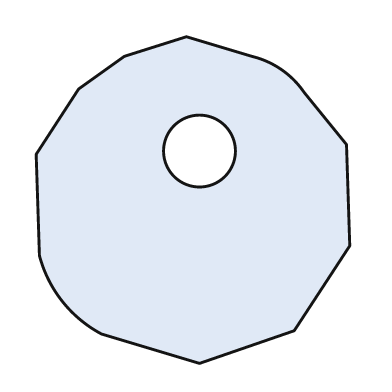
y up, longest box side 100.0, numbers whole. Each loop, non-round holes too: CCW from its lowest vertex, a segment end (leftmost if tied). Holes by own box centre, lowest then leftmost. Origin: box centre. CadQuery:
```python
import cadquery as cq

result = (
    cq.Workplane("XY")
    .moveTo(2.0, -50.0)
    .lineTo(31.0, -40.0)
    .lineTo(48.0, -14.0)
    .lineTo(47.0, 17.0)
    .lineTo(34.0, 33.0)
    .threePointArc((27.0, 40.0), (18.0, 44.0))
    .lineTo(-2.0, 50.0)
    .lineTo(-21.0, 44.0)
    .lineTo(-35.0, 34.0)
    .lineTo(-48.0, 14.0)
    .lineTo(-47.0, -17.0)
    .threePointArc((-40.0, -31.0), (-28.0, -41.0))
    .close()
    .moveTo(2.0, 15.0)
    .circle(11.0)
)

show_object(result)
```